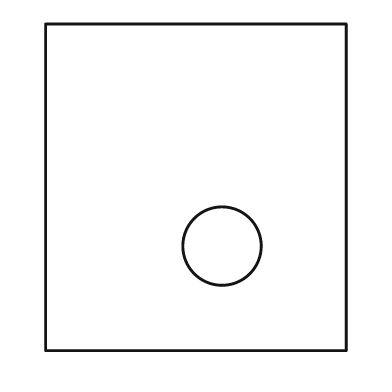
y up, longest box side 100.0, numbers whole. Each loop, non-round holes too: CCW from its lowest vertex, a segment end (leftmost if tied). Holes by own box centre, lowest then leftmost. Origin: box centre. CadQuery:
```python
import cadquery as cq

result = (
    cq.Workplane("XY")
    .moveTo(-46.0, -50.0)
    .lineTo(46.0, -50.0)
    .lineTo(46.0, 50.0)
    .lineTo(-46.0, 50.0)
    .close()
    .moveTo(8.0, -18.0)
    .circle(12.0)
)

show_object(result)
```